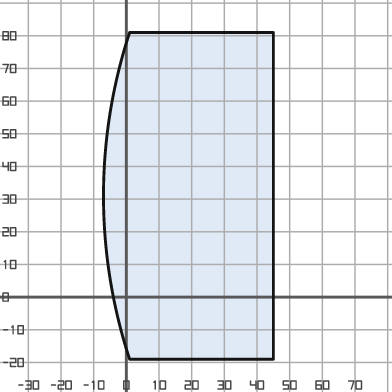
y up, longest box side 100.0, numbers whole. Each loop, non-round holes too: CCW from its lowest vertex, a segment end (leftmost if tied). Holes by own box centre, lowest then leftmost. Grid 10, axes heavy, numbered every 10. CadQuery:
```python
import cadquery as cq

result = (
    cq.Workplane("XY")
    .moveTo(1.0, -19.0)
    .lineTo(45.0, -19.0)
    .lineTo(45.0, 81.0)
    .lineTo(1.0, 81.0)
    .threePointArc((-7.0, 31.0), (1.0, -19.0))
    .close()
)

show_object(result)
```